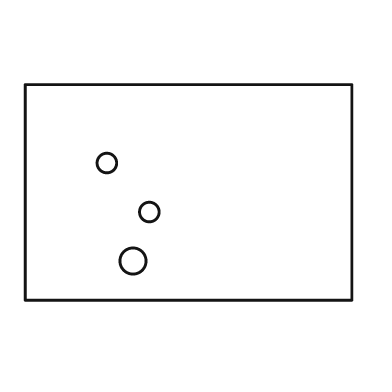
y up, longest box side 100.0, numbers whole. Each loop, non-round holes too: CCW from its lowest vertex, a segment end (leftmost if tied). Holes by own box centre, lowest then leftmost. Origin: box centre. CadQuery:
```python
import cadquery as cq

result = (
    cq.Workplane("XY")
    .moveTo(-50.0, -33.0)
    .lineTo(50.0, -33.0)
    .lineTo(50.0, 33.0)
    .lineTo(-50.0, 33.0)
    .close()
    .moveTo(-17.0, -21.0)
    .circle(4.0)
    .moveTo(-12.0, -6.0)
    .circle(3.0)
    .moveTo(-25.0, 9.0)
    .circle(3.0)
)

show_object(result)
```